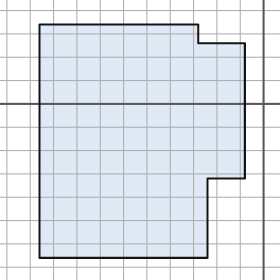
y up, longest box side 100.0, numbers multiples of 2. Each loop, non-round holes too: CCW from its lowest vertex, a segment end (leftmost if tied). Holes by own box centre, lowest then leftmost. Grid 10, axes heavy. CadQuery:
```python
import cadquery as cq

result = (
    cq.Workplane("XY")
    .moveTo(-96.0, -66.0)
    .lineTo(-24.0, -66.0)
    .lineTo(-24.0, -32.0)
    .lineTo(-8.0, -32.0)
    .lineTo(-8.0, 26.0)
    .lineTo(-28.0, 26.0)
    .lineTo(-28.0, 34.0)
    .lineTo(-96.0, 34.0)
    .close()
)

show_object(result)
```